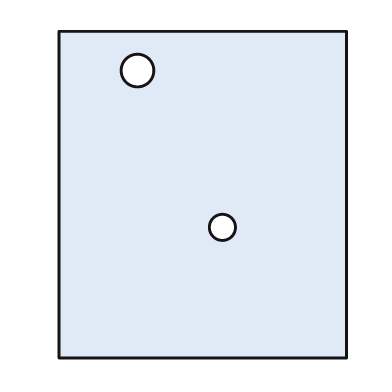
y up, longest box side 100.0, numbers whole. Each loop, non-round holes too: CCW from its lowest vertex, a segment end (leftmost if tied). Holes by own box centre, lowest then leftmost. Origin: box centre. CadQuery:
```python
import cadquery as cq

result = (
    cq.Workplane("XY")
    .moveTo(-44.0, -50.0)
    .lineTo(44.0, -50.0)
    .lineTo(44.0, 50.0)
    .lineTo(-44.0, 50.0)
    .close()
    .moveTo(6.0, -10.0)
    .circle(4.0)
    .moveTo(-20.0, 38.0)
    .circle(5.0)
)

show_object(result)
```